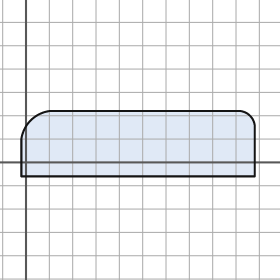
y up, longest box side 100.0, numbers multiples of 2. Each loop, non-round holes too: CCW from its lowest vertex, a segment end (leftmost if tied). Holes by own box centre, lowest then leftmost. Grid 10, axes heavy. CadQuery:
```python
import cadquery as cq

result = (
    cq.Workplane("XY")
    .moveTo(-2.0, -6.0)
    .lineTo(98.0, -6.0)
    .lineTo(98.0, 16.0)
    .threePointArc((96.0, 20.0), (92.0, 22.0))
    .lineTo(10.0, 22.0)
    .threePointArc((2.0, 18.0), (-2.0, 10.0))
    .close()
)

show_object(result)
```